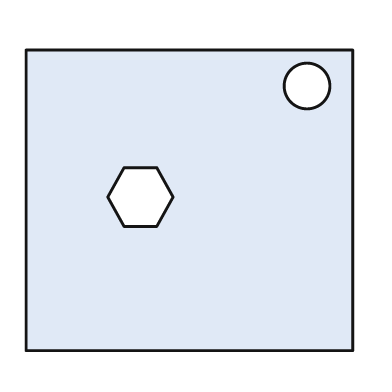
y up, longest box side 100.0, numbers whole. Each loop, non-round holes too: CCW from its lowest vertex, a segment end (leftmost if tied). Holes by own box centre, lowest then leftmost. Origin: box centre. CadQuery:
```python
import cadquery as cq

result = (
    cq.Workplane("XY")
    .moveTo(-50.0, -46.0)
    .lineTo(50.0, -46.0)
    .lineTo(50.0, 46.0)
    .lineTo(-50.0, 46.0)
    .close()
    .moveTo(-20.0, -8.0)
    .lineTo(-10.0, -8.0)
    .lineTo(-5.0, 1.0)
    .lineTo(-10.0, 10.0)
    .lineTo(-20.0, 10.0)
    .lineTo(-25.0, 1.0)
    .close()
    .moveTo(36.0, 35.0)
    .circle(7.0)
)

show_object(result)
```